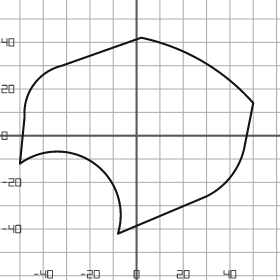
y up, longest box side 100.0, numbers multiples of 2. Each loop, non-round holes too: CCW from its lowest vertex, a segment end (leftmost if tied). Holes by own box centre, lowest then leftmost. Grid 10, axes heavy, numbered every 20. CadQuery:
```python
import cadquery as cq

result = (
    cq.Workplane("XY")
    .moveTo(-8.0, -42.0)
    .lineTo(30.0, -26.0)
    .threePointArc((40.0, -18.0), (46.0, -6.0))
    .lineTo(50.0, 14.0)
    .threePointArc((28.0, 32.0), (2.0, 42.0))
    .lineTo(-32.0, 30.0)
    .threePointArc((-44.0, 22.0), (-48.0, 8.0))
    .lineTo(-50.0, -12.0)
    .threePointArc((-18.0, -12.0), (-8.0, -42.0))
    .close()
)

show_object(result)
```